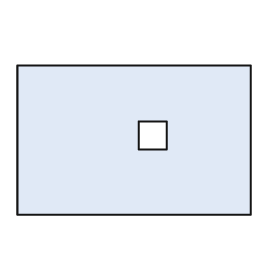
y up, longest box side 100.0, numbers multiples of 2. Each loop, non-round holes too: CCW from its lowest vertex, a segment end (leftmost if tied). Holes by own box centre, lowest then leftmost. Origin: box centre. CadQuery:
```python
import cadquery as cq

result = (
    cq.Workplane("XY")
    .moveTo(-50.0, -32.0)
    .lineTo(50.0, -32.0)
    .lineTo(50.0, 32.0)
    .lineTo(-50.0, 32.0)
    .close()
    .moveTo(2.0, -4.0)
    .lineTo(14.0, -4.0)
    .lineTo(14.0, 8.0)
    .lineTo(2.0, 8.0)
    .close()
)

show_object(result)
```